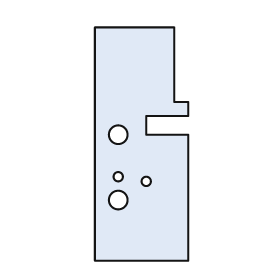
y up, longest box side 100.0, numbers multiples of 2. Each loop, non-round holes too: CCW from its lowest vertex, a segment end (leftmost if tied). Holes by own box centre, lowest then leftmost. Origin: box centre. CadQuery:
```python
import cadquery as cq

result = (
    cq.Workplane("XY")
    .moveTo(-20.0, -50.0)
    .lineTo(20.0, -50.0)
    .lineTo(20.0, 4.0)
    .lineTo(2.0, 4.0)
    .lineTo(2.0, 12.0)
    .lineTo(20.0, 12.0)
    .lineTo(20.0, 18.0)
    .lineTo(14.0, 18.0)
    .lineTo(14.0, 50.0)
    .lineTo(-20.0, 50.0)
    .close()
    .moveTo(-10.0, -24.0)
    .circle(4.0)
    .moveTo(2.0, -16.0)
    .circle(2.0)
    .moveTo(-10.0, -14.0)
    .circle(2.0)
    .moveTo(-10.0, 4.0)
    .circle(4.0)
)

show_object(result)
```